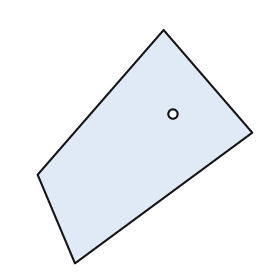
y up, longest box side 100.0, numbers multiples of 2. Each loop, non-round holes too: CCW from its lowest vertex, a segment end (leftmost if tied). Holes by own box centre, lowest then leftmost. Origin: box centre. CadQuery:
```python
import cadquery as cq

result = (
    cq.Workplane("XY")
    .moveTo(-30.0, -50.0)
    .lineTo(46.0, 6.0)
    .lineTo(8.0, 50.0)
    .lineTo(-46.0, -12.0)
    .close()
    .moveTo(12.0, 14.0)
    .circle(2.0)
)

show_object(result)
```